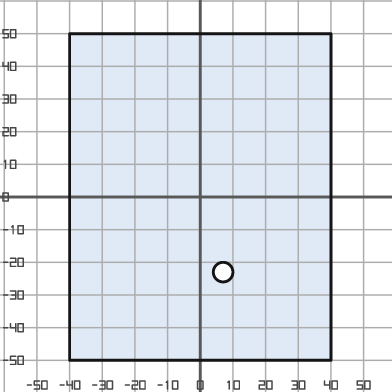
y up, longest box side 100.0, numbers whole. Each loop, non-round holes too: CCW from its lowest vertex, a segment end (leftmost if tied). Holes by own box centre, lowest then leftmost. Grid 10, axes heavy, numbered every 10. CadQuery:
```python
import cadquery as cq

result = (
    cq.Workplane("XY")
    .moveTo(-40.0, -50.0)
    .lineTo(40.0, -50.0)
    .lineTo(40.0, 50.0)
    .lineTo(-40.0, 50.0)
    .close()
    .moveTo(7.0, -23.0)
    .circle(3.0)
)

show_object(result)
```